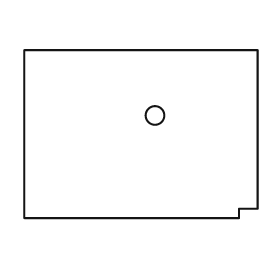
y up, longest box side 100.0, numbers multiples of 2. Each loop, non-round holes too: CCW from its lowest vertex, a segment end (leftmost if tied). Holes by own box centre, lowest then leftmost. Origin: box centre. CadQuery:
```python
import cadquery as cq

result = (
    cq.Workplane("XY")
    .moveTo(-50.0, -36.0)
    .lineTo(42.0, -36.0)
    .lineTo(42.0, -32.0)
    .lineTo(50.0, -32.0)
    .lineTo(50.0, 36.0)
    .lineTo(-50.0, 36.0)
    .close()
    .moveTo(6.0, 8.0)
    .circle(4.0)
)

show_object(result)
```